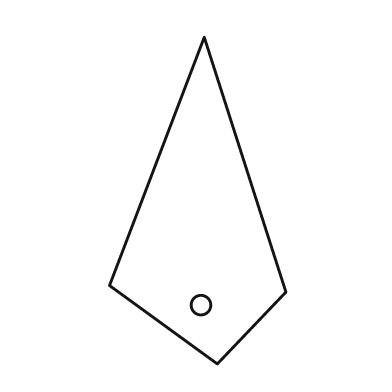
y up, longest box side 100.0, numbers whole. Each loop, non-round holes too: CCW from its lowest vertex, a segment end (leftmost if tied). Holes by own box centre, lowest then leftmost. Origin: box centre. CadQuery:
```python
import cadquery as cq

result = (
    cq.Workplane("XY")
    .moveTo(6.0, -50.0)
    .lineTo(27.0, -28.0)
    .lineTo(2.0, 50.0)
    .lineTo(-27.0, -26.0)
    .close()
    .moveTo(1.0, -32.0)
    .circle(3.0)
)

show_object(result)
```